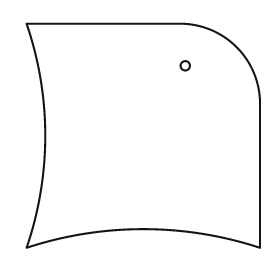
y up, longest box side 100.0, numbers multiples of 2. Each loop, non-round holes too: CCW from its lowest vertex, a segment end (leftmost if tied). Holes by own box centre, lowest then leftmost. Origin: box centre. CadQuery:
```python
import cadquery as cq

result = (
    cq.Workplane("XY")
    .moveTo(-50.0, -48.0)
    .threePointArc((0.0, -40.0), (50.0, -48.0))
    .lineTo(50.0, 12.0)
    .threePointArc((40.0, 38.0), (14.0, 48.0))
    .lineTo(-50.0, 48.0)
    .threePointArc((-42.0, 0.0), (-50.0, -48.0))
    .close()
    .moveTo(18.0, 30.0)
    .circle(2.0)
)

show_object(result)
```